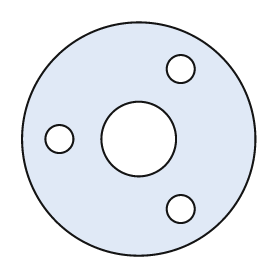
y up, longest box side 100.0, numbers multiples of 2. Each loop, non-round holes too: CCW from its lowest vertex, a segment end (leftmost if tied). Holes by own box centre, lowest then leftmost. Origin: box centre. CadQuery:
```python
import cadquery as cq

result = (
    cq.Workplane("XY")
    .moveTo(0.0, 0.0)
    .circle(50.0)
    .moveTo(18.0, -30.0)
    .circle(6.0)
    .moveTo(-34.0, 0.0)
    .circle(6.0)
    .moveTo(0.0, 0.0)
    .circle(16.0)
    .moveTo(18.0, 30.0)
    .circle(6.0)
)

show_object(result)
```